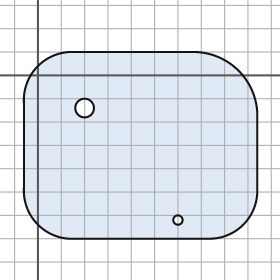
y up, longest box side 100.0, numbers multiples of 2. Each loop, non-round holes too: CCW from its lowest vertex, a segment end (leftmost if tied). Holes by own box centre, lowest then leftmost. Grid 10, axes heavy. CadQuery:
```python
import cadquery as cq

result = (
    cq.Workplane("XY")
    .moveTo(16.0, -70.0)
    .lineTo(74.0, -70.0)
    .threePointArc((88.0, -64.0), (94.0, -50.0))
    .lineTo(94.0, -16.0)
    .threePointArc((86.0, 2.0), (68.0, 10.0))
    .lineTo(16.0, 10.0)
    .threePointArc((0.0, 4.0), (-6.0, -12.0))
    .lineTo(-6.0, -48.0)
    .threePointArc((0.0, -64.0), (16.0, -70.0))
    .close()
    .moveTo(60.0, -62.0)
    .circle(2.0)
    .moveTo(20.0, -14.0)
    .circle(4.0)
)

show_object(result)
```